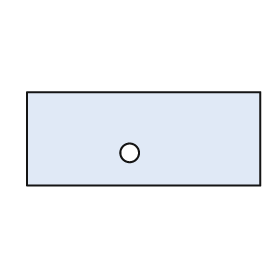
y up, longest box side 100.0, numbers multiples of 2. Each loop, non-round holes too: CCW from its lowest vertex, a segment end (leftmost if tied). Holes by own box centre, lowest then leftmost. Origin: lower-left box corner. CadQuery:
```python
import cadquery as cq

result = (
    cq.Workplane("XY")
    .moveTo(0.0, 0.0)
    .lineTo(100.0, 0.0)
    .lineTo(100.0, 40.0)
    .lineTo(0.0, 40.0)
    .close()
    .moveTo(44.0, 14.0)
    .circle(4.0)
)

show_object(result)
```